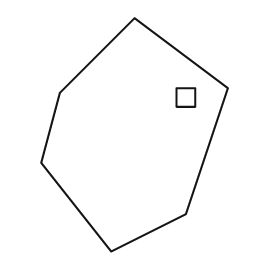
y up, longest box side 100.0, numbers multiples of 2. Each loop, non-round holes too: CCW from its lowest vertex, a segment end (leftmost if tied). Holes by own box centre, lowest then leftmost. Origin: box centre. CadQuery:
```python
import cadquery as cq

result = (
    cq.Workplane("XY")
    .moveTo(-10.0, -50.0)
    .lineTo(22.0, -34.0)
    .lineTo(40.0, 20.0)
    .lineTo(0.0, 50.0)
    .lineTo(-32.0, 18.0)
    .lineTo(-40.0, -12.0)
    .close()
    .moveTo(18.0, 12.0)
    .lineTo(26.0, 12.0)
    .lineTo(26.0, 20.0)
    .lineTo(18.0, 20.0)
    .close()
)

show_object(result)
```